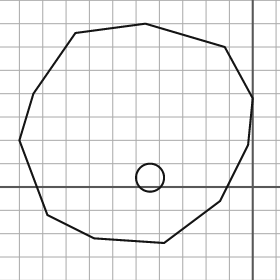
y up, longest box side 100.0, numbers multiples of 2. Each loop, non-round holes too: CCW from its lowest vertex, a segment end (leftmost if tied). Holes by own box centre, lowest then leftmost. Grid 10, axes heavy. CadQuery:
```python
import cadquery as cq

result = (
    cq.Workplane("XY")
    .moveTo(-38.0, -24.0)
    .lineTo(-14.0, -6.0)
    .lineTo(-2.0, 18.0)
    .lineTo(0.0, 38.0)
    .lineTo(-12.0, 60.0)
    .lineTo(-46.0, 70.0)
    .lineTo(-76.0, 66.0)
    .lineTo(-94.0, 40.0)
    .lineTo(-100.0, 20.0)
    .lineTo(-88.0, -12.0)
    .lineTo(-68.0, -22.0)
    .close()
    .moveTo(-44.0, 4.0)
    .circle(6.0)
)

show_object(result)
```